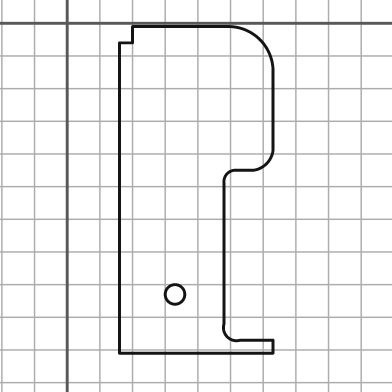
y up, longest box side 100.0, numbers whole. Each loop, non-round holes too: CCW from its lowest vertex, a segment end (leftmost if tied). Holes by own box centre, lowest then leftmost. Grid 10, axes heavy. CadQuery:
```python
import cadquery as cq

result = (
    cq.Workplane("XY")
    .moveTo(16.0, -101.0)
    .lineTo(63.0, -101.0)
    .lineTo(63.0, -97.0)
    .lineTo(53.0, -97.0)
    .threePointArc((49.0, -96.0), (48.0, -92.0))
    .lineTo(48.0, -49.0)
    .threePointArc((49.0, -46.0), (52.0, -45.0))
    .lineTo(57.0, -45.0)
    .threePointArc((61.0, -43.0), (63.0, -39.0))
    .lineTo(63.0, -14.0)
    .threePointArc((59.0, -5.0), (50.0, -1.0))
    .lineTo(20.0, -1.0)
    .lineTo(20.0, -6.0)
    .lineTo(16.0, -6.0)
    .close()
    .moveTo(33.0, -83.0)
    .circle(3.0)
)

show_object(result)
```